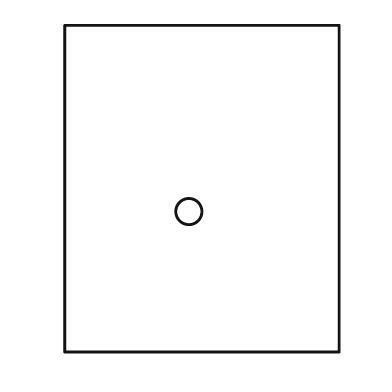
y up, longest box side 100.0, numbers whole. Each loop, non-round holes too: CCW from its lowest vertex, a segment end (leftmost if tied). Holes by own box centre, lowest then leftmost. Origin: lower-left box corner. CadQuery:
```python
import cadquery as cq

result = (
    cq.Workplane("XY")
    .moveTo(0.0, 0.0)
    .lineTo(84.0, 0.0)
    .lineTo(84.0, 100.0)
    .lineTo(0.0, 100.0)
    .close()
    .moveTo(38.0, 43.0)
    .circle(4.0)
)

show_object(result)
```